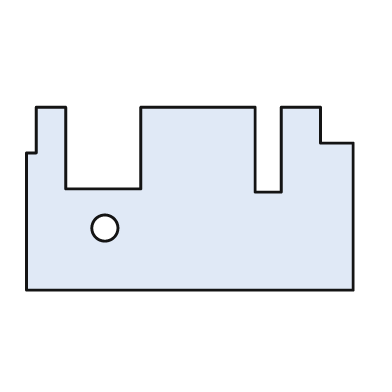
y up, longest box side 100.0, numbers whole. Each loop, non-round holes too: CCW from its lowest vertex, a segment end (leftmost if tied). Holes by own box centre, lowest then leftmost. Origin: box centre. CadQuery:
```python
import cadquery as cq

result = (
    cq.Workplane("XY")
    .moveTo(-50.0, -28.0)
    .lineTo(50.0, -28.0)
    .lineTo(50.0, 17.0)
    .lineTo(40.0, 17.0)
    .lineTo(40.0, 28.0)
    .lineTo(28.0, 28.0)
    .lineTo(28.0, 2.0)
    .lineTo(20.0, 2.0)
    .lineTo(20.0, 28.0)
    .lineTo(-15.0, 28.0)
    .lineTo(-15.0, 3.0)
    .lineTo(-38.0, 3.0)
    .lineTo(-38.0, 28.0)
    .lineTo(-47.0, 28.0)
    .lineTo(-47.0, 14.0)
    .lineTo(-50.0, 14.0)
    .close()
    .moveTo(-26.0, -9.0)
    .circle(4.0)
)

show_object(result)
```